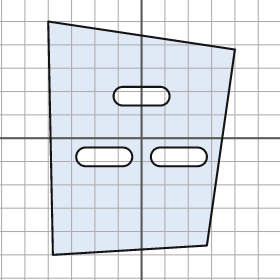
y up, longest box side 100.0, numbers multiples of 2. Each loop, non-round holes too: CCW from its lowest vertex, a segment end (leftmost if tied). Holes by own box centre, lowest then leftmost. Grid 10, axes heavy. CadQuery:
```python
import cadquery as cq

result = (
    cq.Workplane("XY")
    .moveTo(-38.0, -50.0)
    .lineTo(28.0, -46.0)
    .lineTo(40.0, 38.0)
    .lineTo(-40.0, 50.0)
    .close()
    .moveTo(-24.0, -12.0)
    .lineTo(-8.0, -12.0)
    .threePointArc((-4.0, -8.0), (-8.0, -4.0))
    .lineTo(-24.0, -4.0)
    .threePointArc((-28.0, -8.0), (-24.0, -12.0))
    .close()
    .moveTo(8.0, -12.0)
    .lineTo(24.0, -12.0)
    .threePointArc((28.0, -8.0), (24.0, -4.0))
    .lineTo(8.0, -4.0)
    .threePointArc((4.0, -8.0), (8.0, -12.0))
    .close()
    .moveTo(-8.0, 14.0)
    .lineTo(8.0, 14.0)
    .threePointArc((12.0, 18.0), (8.0, 22.0))
    .lineTo(-8.0, 22.0)
    .threePointArc((-12.0, 18.0), (-8.0, 14.0))
    .close()
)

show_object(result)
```